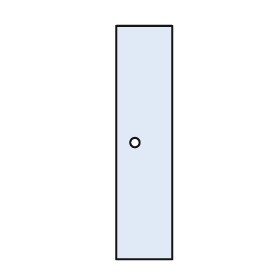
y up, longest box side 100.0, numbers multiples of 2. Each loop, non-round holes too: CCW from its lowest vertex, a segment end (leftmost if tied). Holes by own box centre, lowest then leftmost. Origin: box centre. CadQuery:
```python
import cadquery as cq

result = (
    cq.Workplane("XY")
    .moveTo(-12.0, -50.0)
    .lineTo(12.0, -50.0)
    .lineTo(12.0, 50.0)
    .lineTo(-12.0, 50.0)
    .close()
    .moveTo(-4.0, 0.0)
    .circle(2.0)
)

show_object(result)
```